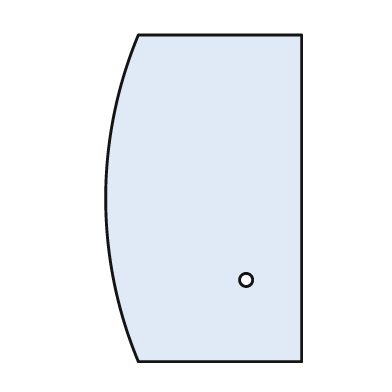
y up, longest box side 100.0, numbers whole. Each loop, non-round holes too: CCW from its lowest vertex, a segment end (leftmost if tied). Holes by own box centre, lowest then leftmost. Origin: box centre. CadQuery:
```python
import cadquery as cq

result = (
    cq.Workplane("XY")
    .moveTo(-20.0, -50.0)
    .lineTo(30.0, -50.0)
    .lineTo(30.0, 50.0)
    .lineTo(-20.0, 50.0)
    .threePointArc((-30.0, 0.0), (-20.0, -50.0))
    .close()
    .moveTo(13.0, -25.0)
    .circle(2.0)
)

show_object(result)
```